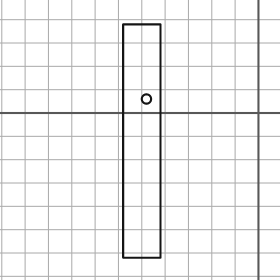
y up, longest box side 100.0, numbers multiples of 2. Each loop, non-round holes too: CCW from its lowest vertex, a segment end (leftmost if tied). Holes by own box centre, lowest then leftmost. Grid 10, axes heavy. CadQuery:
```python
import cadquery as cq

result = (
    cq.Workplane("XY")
    .moveTo(-58.0, -62.0)
    .lineTo(-42.0, -62.0)
    .lineTo(-42.0, 38.0)
    .lineTo(-58.0, 38.0)
    .close()
    .moveTo(-48.0, 6.0)
    .circle(2.0)
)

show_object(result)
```